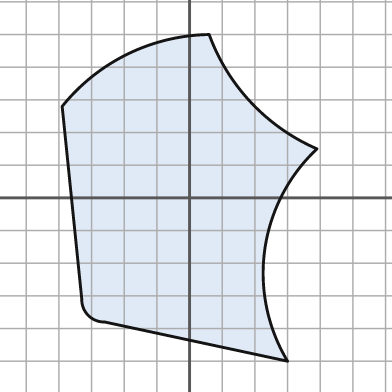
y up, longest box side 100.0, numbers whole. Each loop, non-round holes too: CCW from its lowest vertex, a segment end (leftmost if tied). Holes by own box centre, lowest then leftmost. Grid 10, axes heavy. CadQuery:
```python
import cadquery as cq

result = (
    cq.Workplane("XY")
    .moveTo(30.0, -50.0)
    .threePointArc((23.0, -16.0), (39.0, 15.0))
    .threePointArc((19.0, 29.0), (6.0, 50.0))
    .threePointArc((-19.0, 44.0), (-39.0, 28.0))
    .lineTo(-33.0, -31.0)
    .threePointArc((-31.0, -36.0), (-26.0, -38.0))
    .close()
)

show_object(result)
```